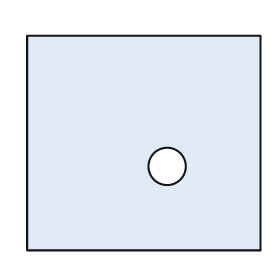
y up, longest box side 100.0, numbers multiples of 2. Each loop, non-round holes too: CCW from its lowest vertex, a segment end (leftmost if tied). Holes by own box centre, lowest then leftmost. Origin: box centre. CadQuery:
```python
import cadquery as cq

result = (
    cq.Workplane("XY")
    .moveTo(-50.0, -46.0)
    .lineTo(50.0, -46.0)
    .lineTo(50.0, 46.0)
    .lineTo(-50.0, 46.0)
    .close()
    .moveTo(10.0, -10.0)
    .circle(8.0)
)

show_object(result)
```